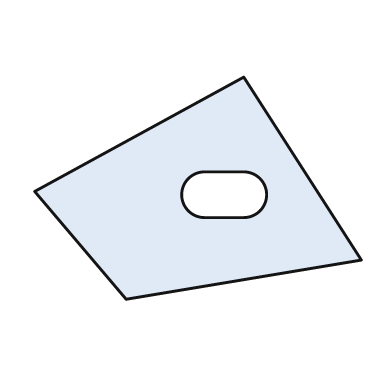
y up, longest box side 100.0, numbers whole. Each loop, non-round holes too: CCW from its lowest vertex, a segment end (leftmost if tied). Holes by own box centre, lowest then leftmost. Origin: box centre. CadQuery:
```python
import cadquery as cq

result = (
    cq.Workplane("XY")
    .moveTo(-22.0, -34.0)
    .lineTo(50.0, -22.0)
    .lineTo(14.0, 34.0)
    .lineTo(-50.0, -1.0)
    .close()
    .moveTo(2.0, -9.0)
    .lineTo(14.0, -9.0)
    .threePointArc((21.0, -2.0), (14.0, 5.0))
    .lineTo(2.0, 5.0)
    .threePointArc((-5.0, -2.0), (2.0, -9.0))
    .close()
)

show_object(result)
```